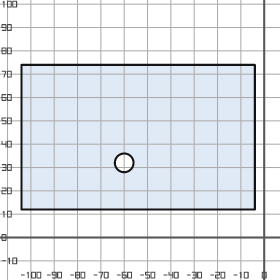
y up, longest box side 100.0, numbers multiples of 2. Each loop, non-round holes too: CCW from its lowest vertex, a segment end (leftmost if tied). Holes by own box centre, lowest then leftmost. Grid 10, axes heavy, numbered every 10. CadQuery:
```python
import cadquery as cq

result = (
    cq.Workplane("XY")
    .moveTo(-104.0, 12.0)
    .lineTo(-4.0, 12.0)
    .lineTo(-4.0, 74.0)
    .lineTo(-104.0, 74.0)
    .close()
    .moveTo(-60.0, 32.0)
    .circle(4.0)
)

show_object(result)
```